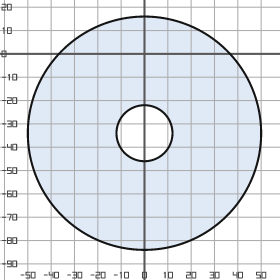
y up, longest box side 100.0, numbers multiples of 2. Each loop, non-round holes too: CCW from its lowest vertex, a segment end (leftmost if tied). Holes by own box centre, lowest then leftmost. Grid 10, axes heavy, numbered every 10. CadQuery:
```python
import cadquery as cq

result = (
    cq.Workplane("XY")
    .moveTo(0.0, -34.0)
    .circle(50.0)
    .moveTo(0.0, -34.0)
    .circle(12.0)
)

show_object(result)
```